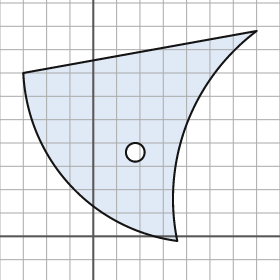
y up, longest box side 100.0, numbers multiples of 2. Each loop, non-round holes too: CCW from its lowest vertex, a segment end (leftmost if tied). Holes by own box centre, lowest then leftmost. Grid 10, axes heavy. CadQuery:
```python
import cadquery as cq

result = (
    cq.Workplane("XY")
    .moveTo(36.0, -2.0)
    .threePointArc((40.0, 48.0), (70.0, 88.0))
    .lineTo(-30.0, 70.0)
    .threePointArc((-10.0, 22.0), (36.0, -2.0))
    .close()
    .moveTo(18.0, 36.0)
    .circle(4.0)
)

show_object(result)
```